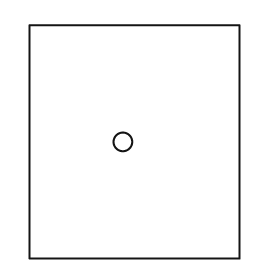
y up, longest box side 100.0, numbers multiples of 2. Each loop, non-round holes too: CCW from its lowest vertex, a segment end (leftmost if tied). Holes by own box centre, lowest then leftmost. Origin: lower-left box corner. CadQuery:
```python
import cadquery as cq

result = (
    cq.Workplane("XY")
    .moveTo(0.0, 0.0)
    .lineTo(90.0, 0.0)
    .lineTo(90.0, 100.0)
    .lineTo(0.0, 100.0)
    .close()
    .moveTo(40.0, 50.0)
    .circle(4.0)
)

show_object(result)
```